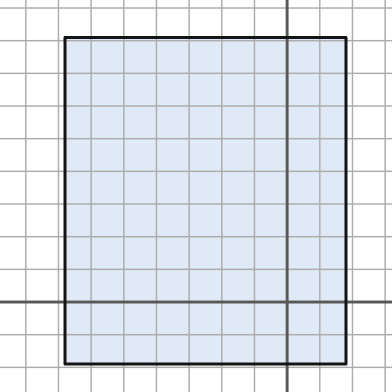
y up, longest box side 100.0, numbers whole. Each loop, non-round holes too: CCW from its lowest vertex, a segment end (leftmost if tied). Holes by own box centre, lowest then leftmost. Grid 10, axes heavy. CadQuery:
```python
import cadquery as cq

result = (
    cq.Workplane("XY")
    .moveTo(-68.0, -19.0)
    .lineTo(18.0, -19.0)
    .lineTo(18.0, 81.0)
    .lineTo(-68.0, 81.0)
    .close()
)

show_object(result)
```